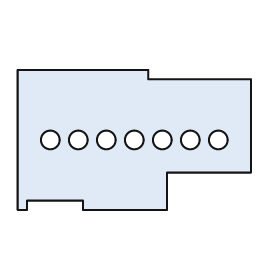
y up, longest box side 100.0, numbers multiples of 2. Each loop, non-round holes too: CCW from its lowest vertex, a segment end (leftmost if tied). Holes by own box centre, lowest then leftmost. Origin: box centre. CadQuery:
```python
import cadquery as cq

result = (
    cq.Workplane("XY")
    .moveTo(-50.0, -30.0)
    .lineTo(-46.0, -30.0)
    .lineTo(-46.0, -26.0)
    .lineTo(-22.0, -26.0)
    .lineTo(-22.0, -30.0)
    .lineTo(14.0, -30.0)
    .lineTo(14.0, -14.0)
    .lineTo(50.0, -14.0)
    .lineTo(50.0, 26.0)
    .lineTo(6.0, 26.0)
    .lineTo(6.0, 30.0)
    .lineTo(-50.0, 30.0)
    .close()
    .moveTo(-36.0, 0.0)
    .circle(4.0)
    .moveTo(-24.0, 0.0)
    .circle(4.0)
    .moveTo(-12.0, 0.0)
    .circle(4.0)
    .moveTo(0.0, 0.0)
    .circle(4.0)
    .moveTo(12.0, 0.0)
    .circle(4.0)
    .moveTo(24.0, 0.0)
    .circle(4.0)
    .moveTo(36.0, 0.0)
    .circle(4.0)
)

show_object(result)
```